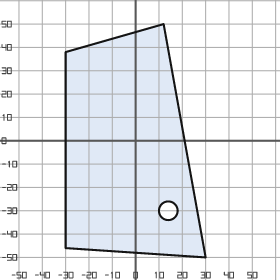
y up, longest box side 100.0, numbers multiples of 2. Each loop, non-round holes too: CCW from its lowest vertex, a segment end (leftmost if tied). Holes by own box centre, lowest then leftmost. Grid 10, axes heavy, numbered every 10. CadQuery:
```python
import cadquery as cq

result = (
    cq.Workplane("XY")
    .moveTo(30.0, -50.0)
    .lineTo(12.0, 50.0)
    .lineTo(-30.0, 38.0)
    .lineTo(-30.0, -46.0)
    .close()
    .moveTo(14.0, -30.0)
    .circle(4.0)
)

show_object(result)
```